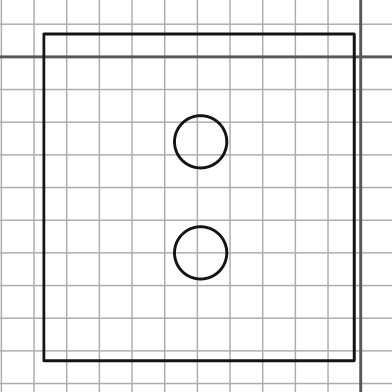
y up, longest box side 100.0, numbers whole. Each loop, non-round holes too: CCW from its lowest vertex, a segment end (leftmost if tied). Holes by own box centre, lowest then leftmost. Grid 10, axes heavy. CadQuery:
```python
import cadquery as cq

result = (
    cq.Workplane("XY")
    .moveTo(-97.0, -93.0)
    .lineTo(-2.0, -93.0)
    .lineTo(-2.0, 7.0)
    .lineTo(-97.0, 7.0)
    .close()
    .moveTo(-49.0, -60.0)
    .circle(8.0)
    .moveTo(-49.0, -26.0)
    .circle(8.0)
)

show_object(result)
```